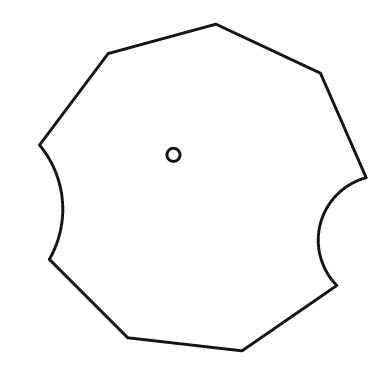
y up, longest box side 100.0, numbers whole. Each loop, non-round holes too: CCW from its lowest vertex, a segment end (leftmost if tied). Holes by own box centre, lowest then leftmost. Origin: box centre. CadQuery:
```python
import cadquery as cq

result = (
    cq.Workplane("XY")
    .moveTo(12.0, -50.0)
    .lineTo(41.0, -30.0)
    .threePointArc((36.0, -11.0), (50.0, 3.0))
    .lineTo(36.0, 35.0)
    .lineTo(4.0, 50.0)
    .lineTo(-29.0, 41.0)
    .lineTo(-50.0, 13.0)
    .threePointArc((-43.0, -4.0), (-47.0, -22.0))
    .lineTo(-23.0, -46.0)
    .close()
    .moveTo(-9.0, 10.0)
    .circle(2.0)
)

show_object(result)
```